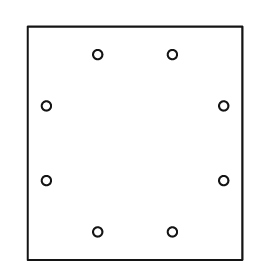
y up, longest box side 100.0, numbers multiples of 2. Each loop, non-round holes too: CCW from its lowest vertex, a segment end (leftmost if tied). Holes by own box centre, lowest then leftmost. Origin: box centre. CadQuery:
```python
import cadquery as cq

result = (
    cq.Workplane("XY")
    .moveTo(-46.0, -50.0)
    .lineTo(46.0, -50.0)
    .lineTo(46.0, 50.0)
    .lineTo(-46.0, 50.0)
    .close()
    .moveTo(-16.0, -38.0)
    .circle(2.0)
    .moveTo(16.0, -38.0)
    .circle(2.0)
    .moveTo(-38.0, -16.0)
    .circle(2.0)
    .moveTo(38.0, -16.0)
    .circle(2.0)
    .moveTo(-38.0, 16.0)
    .circle(2.0)
    .moveTo(38.0, 16.0)
    .circle(2.0)
    .moveTo(-16.0, 38.0)
    .circle(2.0)
    .moveTo(16.0, 38.0)
    .circle(2.0)
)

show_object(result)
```